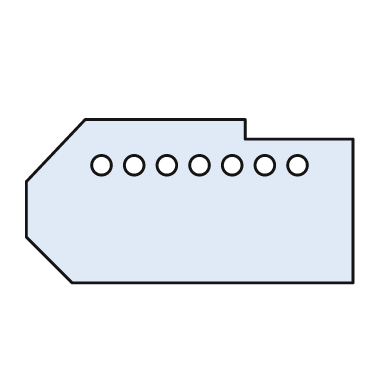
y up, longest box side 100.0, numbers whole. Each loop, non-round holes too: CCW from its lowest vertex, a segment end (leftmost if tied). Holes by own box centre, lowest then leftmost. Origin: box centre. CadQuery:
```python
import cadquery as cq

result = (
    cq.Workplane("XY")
    .moveTo(-36.0, -25.0)
    .lineTo(50.0, -25.0)
    .lineTo(50.0, 19.0)
    .lineTo(17.0, 19.0)
    .lineTo(17.0, 25.0)
    .lineTo(-32.0, 25.0)
    .lineTo(-50.0, 6.0)
    .lineTo(-50.0, -11.0)
    .close()
    .moveTo(-27.0, 11.0)
    .circle(3.0)
    .moveTo(-17.0, 11.0)
    .circle(3.0)
    .moveTo(-7.0, 11.0)
    .circle(3.0)
    .moveTo(3.0, 11.0)
    .circle(3.0)
    .moveTo(13.0, 11.0)
    .circle(3.0)
    .moveTo(23.0, 11.0)
    .circle(3.0)
    .moveTo(33.0, 11.0)
    .circle(3.0)
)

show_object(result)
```